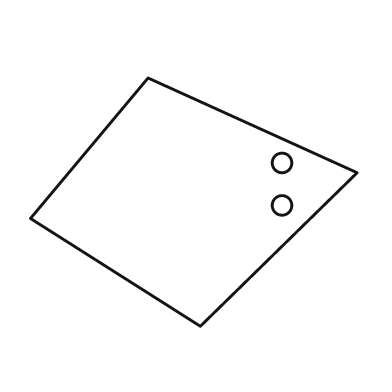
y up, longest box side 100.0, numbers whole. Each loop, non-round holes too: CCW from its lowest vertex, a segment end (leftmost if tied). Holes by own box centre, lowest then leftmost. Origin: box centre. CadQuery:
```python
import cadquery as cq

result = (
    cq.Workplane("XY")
    .moveTo(2.0, -38.0)
    .lineTo(50.0, 9.0)
    .lineTo(-14.0, 38.0)
    .lineTo(-50.0, -5.0)
    .close()
    .moveTo(27.0, -1.0)
    .circle(3.0)
    .moveTo(27.0, 12.0)
    .circle(3.0)
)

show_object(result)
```